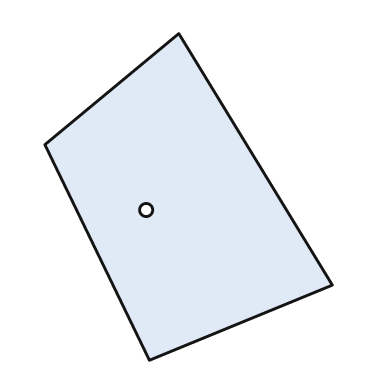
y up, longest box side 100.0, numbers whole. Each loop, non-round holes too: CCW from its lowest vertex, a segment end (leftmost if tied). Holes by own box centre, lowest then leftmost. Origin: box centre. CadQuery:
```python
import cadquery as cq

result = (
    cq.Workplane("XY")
    .moveTo(-12.0, -50.0)
    .lineTo(44.0, -27.0)
    .lineTo(-3.0, 50.0)
    .lineTo(-44.0, 16.0)
    .close()
    .moveTo(-13.0, -4.0)
    .circle(2.0)
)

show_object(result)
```